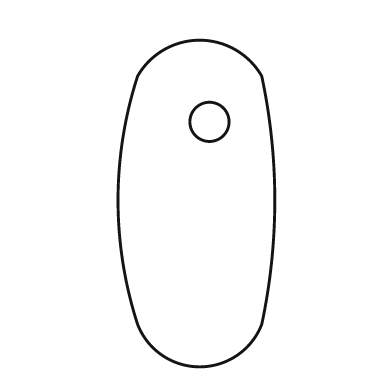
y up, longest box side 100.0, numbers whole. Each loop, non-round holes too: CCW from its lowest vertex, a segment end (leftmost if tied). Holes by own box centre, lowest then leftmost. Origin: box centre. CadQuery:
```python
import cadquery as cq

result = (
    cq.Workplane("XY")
    .moveTo(-18.0, -37.0)
    .threePointArc((1.0, -50.0), (20.0, -37.0))
    .threePointArc((24.0, 1.0), (20.0, 39.0))
    .threePointArc((1.0, 50.0), (-18.0, 39.0))
    .threePointArc((-24.0, 1.0), (-18.0, -37.0))
    .close()
    .moveTo(4.0, 25.0)
    .circle(6.0)
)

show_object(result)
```